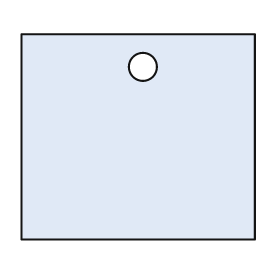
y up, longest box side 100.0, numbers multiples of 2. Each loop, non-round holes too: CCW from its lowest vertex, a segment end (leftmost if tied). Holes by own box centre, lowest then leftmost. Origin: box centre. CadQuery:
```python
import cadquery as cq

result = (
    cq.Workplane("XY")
    .moveTo(-50.0, -44.0)
    .lineTo(50.0, -44.0)
    .lineTo(50.0, 44.0)
    .lineTo(-50.0, 44.0)
    .close()
    .moveTo(2.0, 30.0)
    .circle(6.0)
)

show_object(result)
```